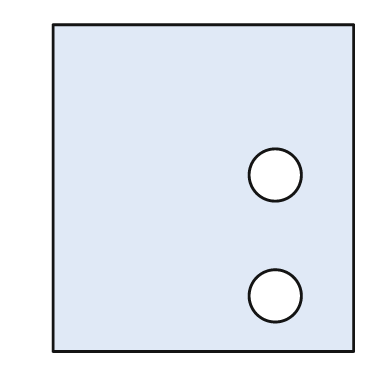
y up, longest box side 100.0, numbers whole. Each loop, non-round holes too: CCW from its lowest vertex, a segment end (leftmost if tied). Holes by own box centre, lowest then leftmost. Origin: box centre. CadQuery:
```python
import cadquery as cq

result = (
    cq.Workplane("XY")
    .moveTo(-46.0, -50.0)
    .lineTo(46.0, -50.0)
    .lineTo(46.0, 50.0)
    .lineTo(-46.0, 50.0)
    .close()
    .moveTo(22.0, -33.0)
    .circle(8.0)
    .moveTo(22.0, 4.0)
    .circle(8.0)
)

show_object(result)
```